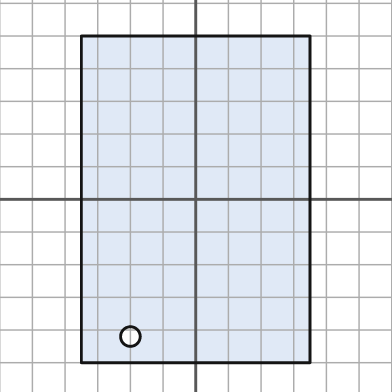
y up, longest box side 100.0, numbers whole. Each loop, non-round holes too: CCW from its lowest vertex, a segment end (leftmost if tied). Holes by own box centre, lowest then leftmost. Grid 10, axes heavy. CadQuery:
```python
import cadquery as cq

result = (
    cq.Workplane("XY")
    .moveTo(-35.0, -50.0)
    .lineTo(35.0, -50.0)
    .lineTo(35.0, 50.0)
    .lineTo(-35.0, 50.0)
    .close()
    .moveTo(-20.0, -42.0)
    .circle(3.0)
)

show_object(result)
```